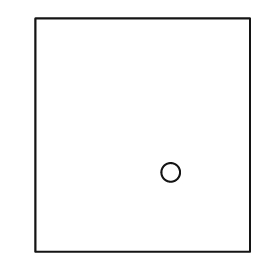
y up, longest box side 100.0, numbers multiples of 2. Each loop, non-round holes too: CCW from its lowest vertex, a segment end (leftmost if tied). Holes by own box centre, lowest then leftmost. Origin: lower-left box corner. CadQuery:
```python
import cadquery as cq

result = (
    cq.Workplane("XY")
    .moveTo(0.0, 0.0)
    .lineTo(92.0, 0.0)
    .lineTo(92.0, 100.0)
    .lineTo(0.0, 100.0)
    .close()
    .moveTo(58.0, 34.0)
    .circle(4.0)
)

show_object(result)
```